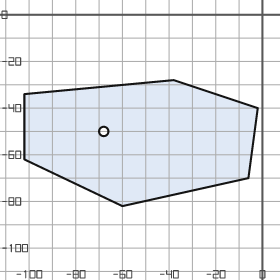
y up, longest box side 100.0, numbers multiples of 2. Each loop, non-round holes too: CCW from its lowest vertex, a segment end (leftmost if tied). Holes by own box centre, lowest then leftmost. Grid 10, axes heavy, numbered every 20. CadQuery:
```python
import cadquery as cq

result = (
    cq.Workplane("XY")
    .moveTo(-60.0, -82.0)
    .lineTo(-6.0, -70.0)
    .lineTo(-2.0, -40.0)
    .lineTo(-38.0, -28.0)
    .lineTo(-102.0, -34.0)
    .lineTo(-102.0, -62.0)
    .close()
    .moveTo(-68.0, -50.0)
    .circle(2.0)
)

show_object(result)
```